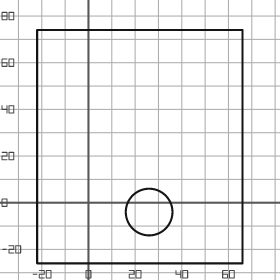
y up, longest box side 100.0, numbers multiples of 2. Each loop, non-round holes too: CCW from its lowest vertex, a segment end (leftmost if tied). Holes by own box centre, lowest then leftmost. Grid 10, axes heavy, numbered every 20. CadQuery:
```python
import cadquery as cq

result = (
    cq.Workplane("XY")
    .moveTo(-22.0, -26.0)
    .lineTo(66.0, -26.0)
    .lineTo(66.0, 74.0)
    .lineTo(-22.0, 74.0)
    .close()
    .moveTo(26.0, -4.0)
    .circle(10.0)
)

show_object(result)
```